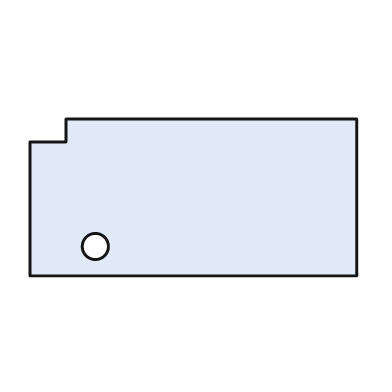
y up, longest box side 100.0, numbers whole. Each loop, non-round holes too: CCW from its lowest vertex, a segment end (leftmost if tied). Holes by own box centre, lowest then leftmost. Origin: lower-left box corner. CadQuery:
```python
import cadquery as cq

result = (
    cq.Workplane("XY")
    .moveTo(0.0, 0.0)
    .lineTo(100.0, 0.0)
    .lineTo(100.0, 48.0)
    .lineTo(11.0, 48.0)
    .lineTo(11.0, 41.0)
    .lineTo(0.0, 41.0)
    .close()
    .moveTo(20.0, 9.0)
    .circle(4.0)
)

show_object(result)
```